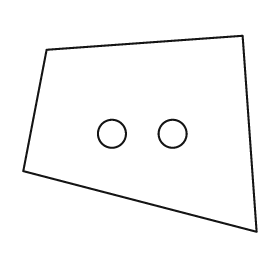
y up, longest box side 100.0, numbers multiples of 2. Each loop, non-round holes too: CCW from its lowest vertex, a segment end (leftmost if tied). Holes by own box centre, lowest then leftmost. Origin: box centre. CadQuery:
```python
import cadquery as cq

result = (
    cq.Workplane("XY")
    .moveTo(50.0, -42.0)
    .lineTo(44.0, 42.0)
    .lineTo(-40.0, 36.0)
    .lineTo(-50.0, -16.0)
    .close()
    .moveTo(-12.0, 0.0)
    .circle(6.0)
    .moveTo(14.0, 0.0)
    .circle(6.0)
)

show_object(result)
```